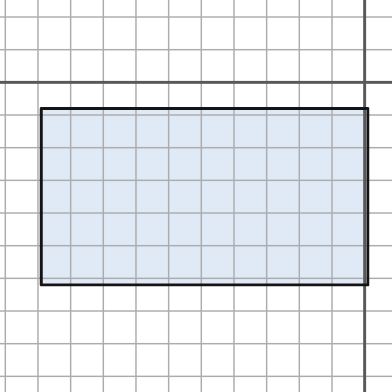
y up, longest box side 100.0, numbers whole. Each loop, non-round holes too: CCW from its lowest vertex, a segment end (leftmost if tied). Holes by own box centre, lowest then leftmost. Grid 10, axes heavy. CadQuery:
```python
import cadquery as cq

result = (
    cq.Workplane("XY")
    .moveTo(-99.0, -62.0)
    .lineTo(1.0, -62.0)
    .lineTo(1.0, -8.0)
    .lineTo(-99.0, -8.0)
    .close()
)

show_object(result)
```